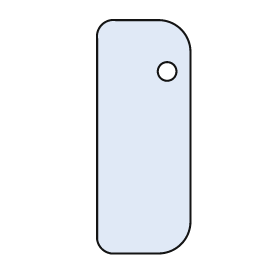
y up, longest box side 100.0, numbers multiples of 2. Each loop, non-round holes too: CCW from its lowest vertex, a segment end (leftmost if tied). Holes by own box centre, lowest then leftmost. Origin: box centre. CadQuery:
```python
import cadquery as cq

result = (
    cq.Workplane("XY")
    .moveTo(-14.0, -50.0)
    .lineTo(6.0, -50.0)
    .threePointArc((16.0, -46.0), (20.0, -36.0))
    .lineTo(20.0, 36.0)
    .threePointArc((16.0, 46.0), (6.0, 50.0))
    .lineTo(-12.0, 50.0)
    .threePointArc((-18.0, 48.0), (-20.0, 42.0))
    .lineTo(-20.0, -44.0)
    .threePointArc((-18.0, -48.0), (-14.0, -50.0))
    .close()
    .moveTo(10.0, 28.0)
    .circle(4.0)
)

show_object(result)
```